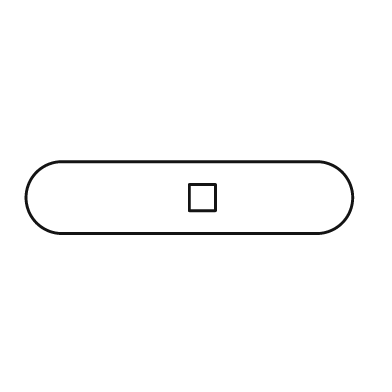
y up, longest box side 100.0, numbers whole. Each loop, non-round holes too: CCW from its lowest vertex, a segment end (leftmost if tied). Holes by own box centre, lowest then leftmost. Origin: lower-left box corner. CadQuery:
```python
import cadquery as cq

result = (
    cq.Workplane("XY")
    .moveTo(11.0, 0.0)
    .lineTo(89.0, 0.0)
    .threePointArc((100.0, 11.0), (89.0, 22.0))
    .lineTo(11.0, 22.0)
    .threePointArc((0.0, 11.0), (11.0, 0.0))
    .close()
    .moveTo(50.0, 7.0)
    .lineTo(58.0, 7.0)
    .lineTo(58.0, 15.0)
    .lineTo(50.0, 15.0)
    .close()
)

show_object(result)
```